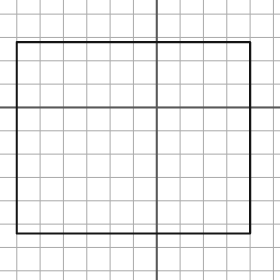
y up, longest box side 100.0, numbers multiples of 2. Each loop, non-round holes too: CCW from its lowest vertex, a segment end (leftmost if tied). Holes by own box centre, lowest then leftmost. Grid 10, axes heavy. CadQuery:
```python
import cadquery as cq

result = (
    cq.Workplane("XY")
    .moveTo(-60.0, -54.0)
    .lineTo(40.0, -54.0)
    .lineTo(40.0, 28.0)
    .lineTo(-60.0, 28.0)
    .close()
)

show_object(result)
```